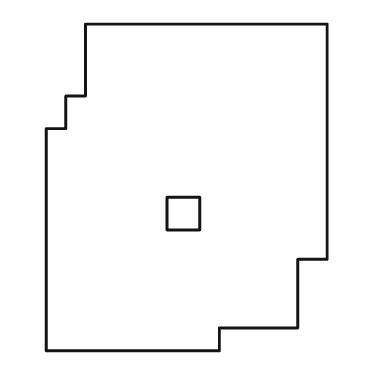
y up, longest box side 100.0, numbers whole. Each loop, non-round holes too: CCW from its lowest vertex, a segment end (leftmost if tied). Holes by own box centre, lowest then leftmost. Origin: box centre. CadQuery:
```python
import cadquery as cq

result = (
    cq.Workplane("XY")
    .moveTo(-43.0, -50.0)
    .lineTo(10.0, -50.0)
    .lineTo(10.0, -43.0)
    .lineTo(34.0, -43.0)
    .lineTo(34.0, -22.0)
    .lineTo(43.0, -22.0)
    .lineTo(43.0, 50.0)
    .lineTo(-31.0, 50.0)
    .lineTo(-31.0, 28.0)
    .lineTo(-37.0, 28.0)
    .lineTo(-37.0, 18.0)
    .lineTo(-43.0, 18.0)
    .close()
    .moveTo(-6.0, -13.0)
    .lineTo(4.0, -13.0)
    .lineTo(4.0, -3.0)
    .lineTo(-6.0, -3.0)
    .close()
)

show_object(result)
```